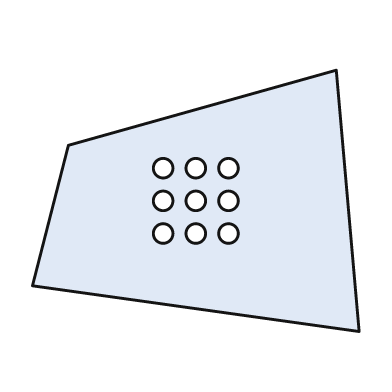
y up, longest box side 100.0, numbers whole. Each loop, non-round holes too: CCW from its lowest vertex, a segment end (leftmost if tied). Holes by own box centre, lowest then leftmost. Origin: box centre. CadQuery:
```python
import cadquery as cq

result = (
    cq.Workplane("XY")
    .moveTo(50.0, -40.0)
    .lineTo(43.0, 40.0)
    .lineTo(-39.0, 17.0)
    .lineTo(-50.0, -26.0)
    .close()
    .moveTo(-10.0, -10.0)
    .circle(3.0)
    .moveTo(0.0, -10.0)
    .circle(3.0)
    .moveTo(10.0, -10.0)
    .circle(3.0)
    .moveTo(-10.0, 0.0)
    .circle(3.0)
    .moveTo(0.0, 0.0)
    .circle(3.0)
    .moveTo(10.0, 0.0)
    .circle(3.0)
    .moveTo(-10.0, 10.0)
    .circle(3.0)
    .moveTo(0.0, 10.0)
    .circle(3.0)
    .moveTo(10.0, 10.0)
    .circle(3.0)
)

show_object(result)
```